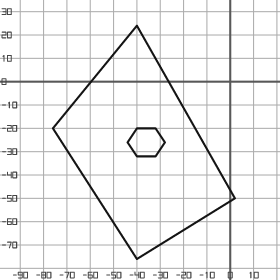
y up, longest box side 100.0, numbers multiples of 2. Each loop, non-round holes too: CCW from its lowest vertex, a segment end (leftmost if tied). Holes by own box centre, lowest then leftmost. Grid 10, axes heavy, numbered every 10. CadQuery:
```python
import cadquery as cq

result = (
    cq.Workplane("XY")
    .moveTo(-40.0, -76.0)
    .lineTo(2.0, -50.0)
    .lineTo(-40.0, 24.0)
    .lineTo(-76.0, -20.0)
    .close()
    .moveTo(-40.0, -32.0)
    .lineTo(-32.0, -32.0)
    .lineTo(-28.0, -26.0)
    .lineTo(-32.0, -20.0)
    .lineTo(-40.0, -20.0)
    .lineTo(-44.0, -26.0)
    .close()
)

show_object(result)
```